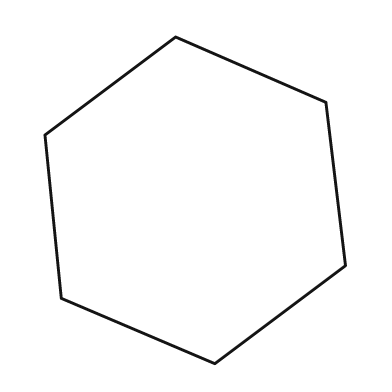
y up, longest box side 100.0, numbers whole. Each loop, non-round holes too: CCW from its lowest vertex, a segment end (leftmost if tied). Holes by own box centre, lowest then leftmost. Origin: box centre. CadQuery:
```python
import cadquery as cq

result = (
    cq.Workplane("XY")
    .moveTo(6.0, -50.0)
    .lineTo(46.0, -20.0)
    .lineTo(40.0, 30.0)
    .lineTo(-6.0, 50.0)
    .lineTo(-46.0, 20.0)
    .lineTo(-41.0, -30.0)
    .close()
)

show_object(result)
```